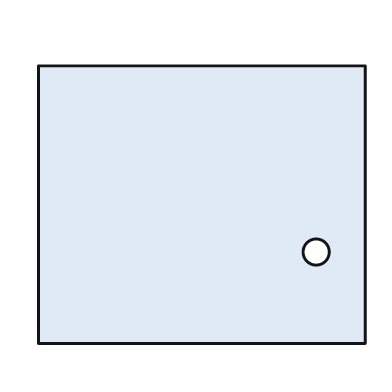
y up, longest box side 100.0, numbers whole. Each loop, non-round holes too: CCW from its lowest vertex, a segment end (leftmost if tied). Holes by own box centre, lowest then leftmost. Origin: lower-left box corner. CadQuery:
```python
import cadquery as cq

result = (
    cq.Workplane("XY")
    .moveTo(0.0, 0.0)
    .lineTo(100.0, 0.0)
    .lineTo(100.0, 85.0)
    .lineTo(0.0, 85.0)
    .close()
    .moveTo(85.0, 28.0)
    .circle(4.0)
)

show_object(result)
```